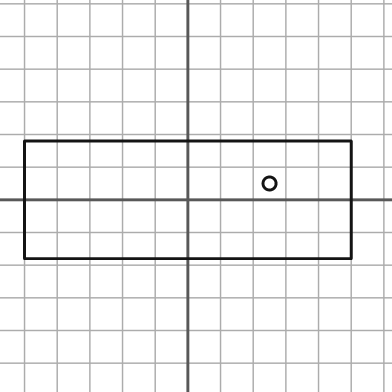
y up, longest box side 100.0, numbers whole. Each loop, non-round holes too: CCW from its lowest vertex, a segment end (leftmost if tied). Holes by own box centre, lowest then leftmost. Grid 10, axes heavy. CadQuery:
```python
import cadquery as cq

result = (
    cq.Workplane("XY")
    .moveTo(-50.0, -18.0)
    .lineTo(50.0, -18.0)
    .lineTo(50.0, 18.0)
    .lineTo(-50.0, 18.0)
    .close()
    .moveTo(25.0, 5.0)
    .circle(2.0)
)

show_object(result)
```